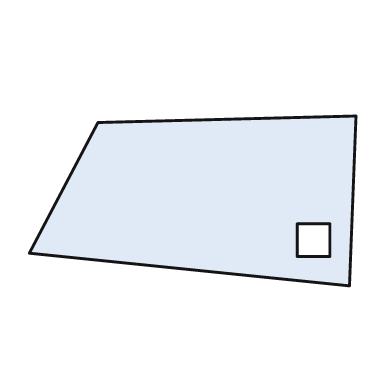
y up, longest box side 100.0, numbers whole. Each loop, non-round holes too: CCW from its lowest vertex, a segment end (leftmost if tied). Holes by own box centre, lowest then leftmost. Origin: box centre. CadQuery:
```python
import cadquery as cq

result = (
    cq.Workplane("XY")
    .moveTo(48.0, -26.0)
    .lineTo(50.0, 26.0)
    .lineTo(-29.0, 24.0)
    .lineTo(-50.0, -16.0)
    .close()
    .moveTo(32.0, -17.0)
    .lineTo(42.0, -17.0)
    .lineTo(42.0, -7.0)
    .lineTo(32.0, -7.0)
    .close()
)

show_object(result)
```